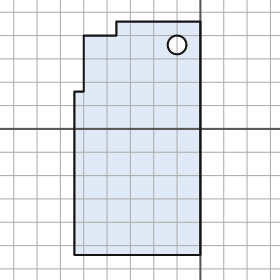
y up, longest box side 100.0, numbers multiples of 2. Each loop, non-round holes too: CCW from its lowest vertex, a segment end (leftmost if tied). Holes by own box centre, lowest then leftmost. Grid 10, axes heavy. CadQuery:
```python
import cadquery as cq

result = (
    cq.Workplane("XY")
    .moveTo(-54.0, -54.0)
    .lineTo(0.0, -54.0)
    .lineTo(0.0, 46.0)
    .lineTo(-36.0, 46.0)
    .lineTo(-36.0, 40.0)
    .lineTo(-50.0, 40.0)
    .lineTo(-50.0, 16.0)
    .lineTo(-54.0, 16.0)
    .close()
    .moveTo(-10.0, 36.0)
    .circle(4.0)
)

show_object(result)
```